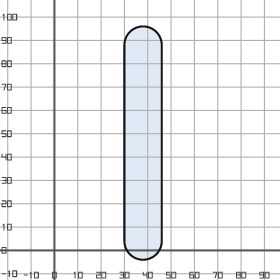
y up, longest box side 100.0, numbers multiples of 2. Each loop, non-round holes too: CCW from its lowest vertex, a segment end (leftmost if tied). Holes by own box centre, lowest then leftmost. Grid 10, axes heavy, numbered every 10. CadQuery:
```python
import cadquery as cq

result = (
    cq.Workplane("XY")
    .moveTo(30.0, 4.0)
    .threePointArc((38.0, -4.0), (46.0, 4.0))
    .lineTo(46.0, 88.0)
    .threePointArc((38.0, 96.0), (30.0, 88.0))
    .close()
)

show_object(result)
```